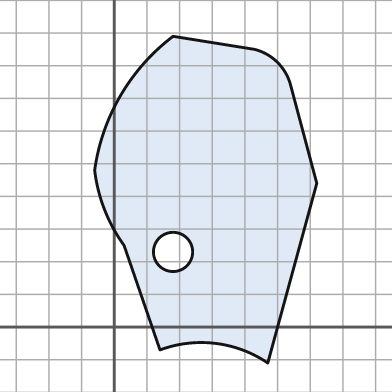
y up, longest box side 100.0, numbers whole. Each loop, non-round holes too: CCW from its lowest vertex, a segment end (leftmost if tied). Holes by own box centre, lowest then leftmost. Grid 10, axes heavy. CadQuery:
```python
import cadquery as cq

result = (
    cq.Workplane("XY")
    .moveTo(47.0, -11.0)
    .lineTo(62.0, 44.0)
    .lineTo(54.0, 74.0)
    .threePointArc((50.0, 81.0), (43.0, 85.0))
    .lineTo(18.0, 89.0)
    .threePointArc((2.0, 71.0), (-6.0, 48.0))
    .threePointArc((-3.0, 36.0), (3.0, 25.0))
    .lineTo(14.0, -7.0)
    .threePointArc((31.0, -5.0), (47.0, -11.0))
    .close()
    .moveTo(18.0, 23.0)
    .circle(6.0)
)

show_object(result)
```